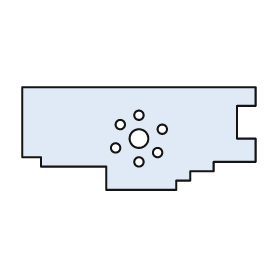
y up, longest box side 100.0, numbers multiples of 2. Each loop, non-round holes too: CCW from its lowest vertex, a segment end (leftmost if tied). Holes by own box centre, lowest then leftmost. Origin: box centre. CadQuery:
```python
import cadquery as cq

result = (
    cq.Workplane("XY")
    .moveTo(-14.0, -22.0)
    .lineTo(16.0, -22.0)
    .lineTo(16.0, -18.0)
    .lineTo(22.0, -18.0)
    .lineTo(22.0, -14.0)
    .lineTo(32.0, -14.0)
    .lineTo(32.0, -10.0)
    .lineTo(50.0, -10.0)
    .lineTo(50.0, 0.0)
    .lineTo(42.0, 0.0)
    .lineTo(42.0, 14.0)
    .lineTo(50.0, 14.0)
    .lineTo(50.0, 22.0)
    .lineTo(-50.0, 22.0)
    .lineTo(-50.0, -8.0)
    .lineTo(-42.0, -8.0)
    .lineTo(-42.0, -12.0)
    .lineTo(-14.0, -12.0)
    .close()
    .moveTo(0.0, -10.0)
    .circle(2.0)
    .moveTo(8.0, -6.0)
    .circle(2.0)
    .moveTo(-10.0, -4.0)
    .circle(2.0)
    .moveTo(0.0, 0.0)
    .circle(4.0)
    .moveTo(10.0, 4.0)
    .circle(2.0)
    .moveTo(-8.0, 6.0)
    .circle(2.0)
    .moveTo(0.0, 10.0)
    .circle(2.0)
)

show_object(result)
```